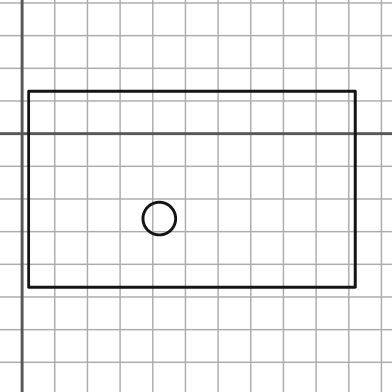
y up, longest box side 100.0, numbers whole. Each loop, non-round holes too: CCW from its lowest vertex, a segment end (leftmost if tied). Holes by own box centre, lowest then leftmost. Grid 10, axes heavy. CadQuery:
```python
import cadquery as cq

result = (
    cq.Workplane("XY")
    .moveTo(2.0, -47.0)
    .lineTo(102.0, -47.0)
    .lineTo(102.0, 13.0)
    .lineTo(2.0, 13.0)
    .close()
    .moveTo(42.0, -26.0)
    .circle(5.0)
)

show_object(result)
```